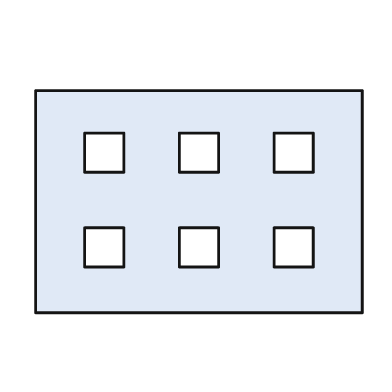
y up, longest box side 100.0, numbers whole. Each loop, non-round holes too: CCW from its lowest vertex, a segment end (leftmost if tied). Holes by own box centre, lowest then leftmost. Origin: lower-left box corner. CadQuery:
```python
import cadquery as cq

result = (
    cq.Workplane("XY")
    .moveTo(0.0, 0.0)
    .lineTo(100.0, 0.0)
    .lineTo(100.0, 68.0)
    .lineTo(0.0, 68.0)
    .close()
    .moveTo(15.0, 14.0)
    .lineTo(27.0, 14.0)
    .lineTo(27.0, 26.0)
    .lineTo(15.0, 26.0)
    .close()
    .moveTo(44.0, 14.0)
    .lineTo(56.0, 14.0)
    .lineTo(56.0, 26.0)
    .lineTo(44.0, 26.0)
    .close()
    .moveTo(73.0, 14.0)
    .lineTo(85.0, 14.0)
    .lineTo(85.0, 26.0)
    .lineTo(73.0, 26.0)
    .close()
    .moveTo(15.0, 43.0)
    .lineTo(27.0, 43.0)
    .lineTo(27.0, 55.0)
    .lineTo(15.0, 55.0)
    .close()
    .moveTo(44.0, 43.0)
    .lineTo(56.0, 43.0)
    .lineTo(56.0, 55.0)
    .lineTo(44.0, 55.0)
    .close()
    .moveTo(73.0, 43.0)
    .lineTo(85.0, 43.0)
    .lineTo(85.0, 55.0)
    .lineTo(73.0, 55.0)
    .close()
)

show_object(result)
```